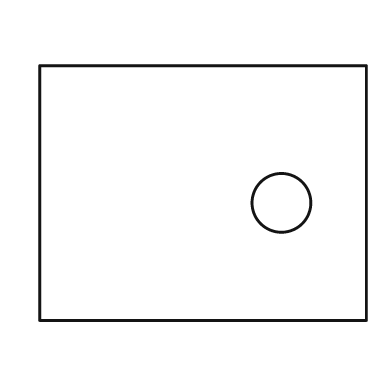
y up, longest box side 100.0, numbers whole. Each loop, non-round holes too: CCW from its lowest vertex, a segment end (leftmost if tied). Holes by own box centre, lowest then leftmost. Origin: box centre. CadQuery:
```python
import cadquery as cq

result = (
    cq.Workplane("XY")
    .moveTo(-50.0, -39.0)
    .lineTo(50.0, -39.0)
    .lineTo(50.0, 39.0)
    .lineTo(-50.0, 39.0)
    .close()
    .moveTo(24.0, -3.0)
    .circle(9.0)
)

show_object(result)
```